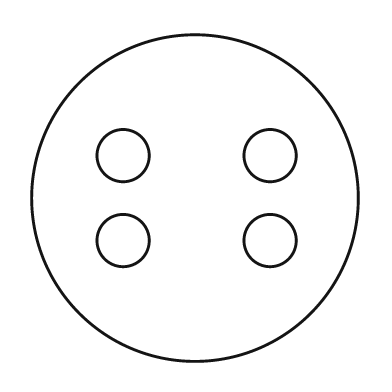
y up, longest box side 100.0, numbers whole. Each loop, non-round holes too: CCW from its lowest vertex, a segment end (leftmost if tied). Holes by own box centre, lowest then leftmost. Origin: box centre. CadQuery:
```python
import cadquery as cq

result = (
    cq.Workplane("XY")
    .moveTo(0.0, 0.0)
    .circle(50.0)
    .moveTo(-22.0, -13.0)
    .circle(8.0)
    .moveTo(23.0, -13.0)
    .circle(8.0)
    .moveTo(-22.0, 13.0)
    .circle(8.0)
    .moveTo(23.0, 13.0)
    .circle(8.0)
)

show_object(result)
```